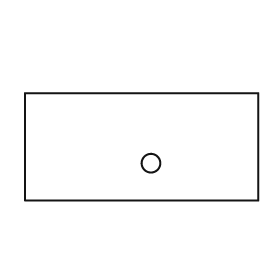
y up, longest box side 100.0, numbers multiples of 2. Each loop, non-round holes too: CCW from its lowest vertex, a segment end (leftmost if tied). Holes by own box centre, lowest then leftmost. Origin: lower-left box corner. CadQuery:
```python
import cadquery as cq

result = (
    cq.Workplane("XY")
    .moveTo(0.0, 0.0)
    .lineTo(100.0, 0.0)
    .lineTo(100.0, 46.0)
    .lineTo(0.0, 46.0)
    .close()
    .moveTo(54.0, 16.0)
    .circle(4.0)
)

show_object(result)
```